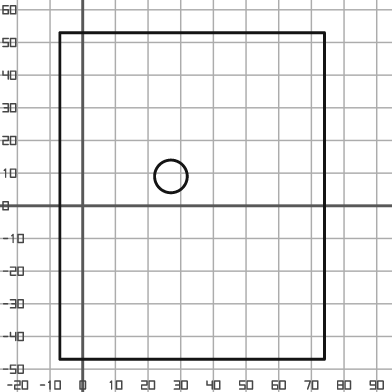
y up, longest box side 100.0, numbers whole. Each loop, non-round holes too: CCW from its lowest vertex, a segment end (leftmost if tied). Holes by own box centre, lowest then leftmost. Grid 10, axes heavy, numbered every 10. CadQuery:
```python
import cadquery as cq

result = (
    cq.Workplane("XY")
    .moveTo(-7.0, -47.0)
    .lineTo(74.0, -47.0)
    .lineTo(74.0, 53.0)
    .lineTo(-7.0, 53.0)
    .close()
    .moveTo(27.0, 9.0)
    .circle(5.0)
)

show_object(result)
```